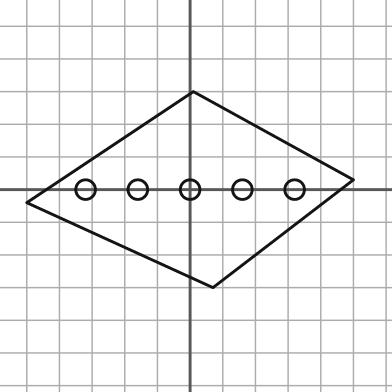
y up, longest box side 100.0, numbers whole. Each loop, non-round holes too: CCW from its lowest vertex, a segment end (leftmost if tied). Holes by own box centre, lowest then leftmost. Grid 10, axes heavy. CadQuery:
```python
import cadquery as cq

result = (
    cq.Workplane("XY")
    .moveTo(7.0, -30.0)
    .lineTo(50.0, 3.0)
    .lineTo(1.0, 30.0)
    .lineTo(-50.0, -4.0)
    .close()
    .moveTo(-32.0, 0.0)
    .circle(3.0)
    .moveTo(-16.0, 0.0)
    .circle(3.0)
    .moveTo(0.0, 0.0)
    .circle(3.0)
    .moveTo(16.0, 0.0)
    .circle(3.0)
    .moveTo(32.0, 0.0)
    .circle(3.0)
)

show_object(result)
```